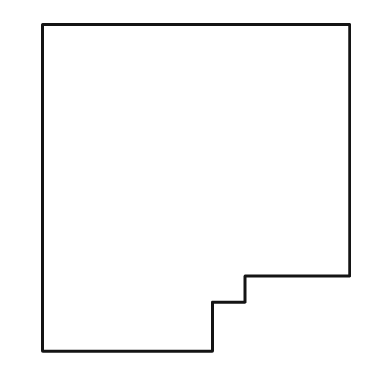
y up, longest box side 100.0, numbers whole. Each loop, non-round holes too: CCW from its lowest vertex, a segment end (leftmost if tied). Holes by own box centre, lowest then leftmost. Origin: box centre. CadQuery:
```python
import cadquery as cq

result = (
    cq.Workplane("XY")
    .moveTo(-47.0, -50.0)
    .lineTo(5.0, -50.0)
    .lineTo(5.0, -35.0)
    .lineTo(15.0, -35.0)
    .lineTo(15.0, -27.0)
    .lineTo(47.0, -27.0)
    .lineTo(47.0, 50.0)
    .lineTo(-47.0, 50.0)
    .close()
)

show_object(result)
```